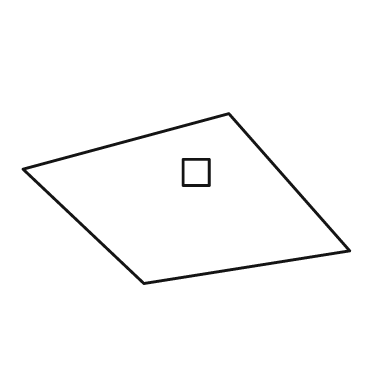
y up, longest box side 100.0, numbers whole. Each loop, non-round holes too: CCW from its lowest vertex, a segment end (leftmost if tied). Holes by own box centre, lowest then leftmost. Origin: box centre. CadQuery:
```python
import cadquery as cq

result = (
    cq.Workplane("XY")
    .moveTo(-13.0, -26.0)
    .lineTo(50.0, -16.0)
    .lineTo(13.0, 26.0)
    .lineTo(-50.0, 9.0)
    .close()
    .moveTo(-1.0, 4.0)
    .lineTo(7.0, 4.0)
    .lineTo(7.0, 12.0)
    .lineTo(-1.0, 12.0)
    .close()
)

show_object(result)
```